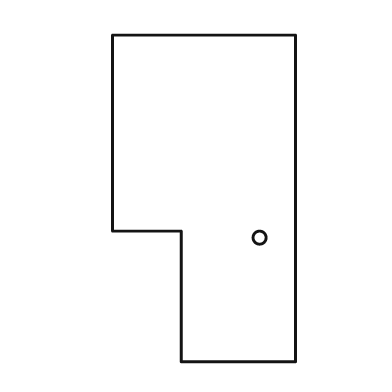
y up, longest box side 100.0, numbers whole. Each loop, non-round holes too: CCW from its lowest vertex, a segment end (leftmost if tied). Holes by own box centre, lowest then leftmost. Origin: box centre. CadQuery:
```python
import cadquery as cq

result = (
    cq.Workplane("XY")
    .moveTo(-7.0, -50.0)
    .lineTo(28.0, -50.0)
    .lineTo(28.0, 50.0)
    .lineTo(-28.0, 50.0)
    .lineTo(-28.0, -10.0)
    .lineTo(-7.0, -10.0)
    .close()
    .moveTo(17.0, -12.0)
    .circle(2.0)
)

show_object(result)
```